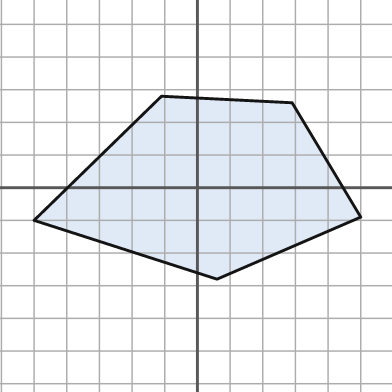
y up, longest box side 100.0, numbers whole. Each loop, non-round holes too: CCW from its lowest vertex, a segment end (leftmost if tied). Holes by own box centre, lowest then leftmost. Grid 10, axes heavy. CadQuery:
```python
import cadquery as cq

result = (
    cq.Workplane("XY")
    .moveTo(6.0, -28.0)
    .lineTo(50.0, -9.0)
    .lineTo(29.0, 26.0)
    .lineTo(-11.0, 28.0)
    .lineTo(-50.0, -10.0)
    .close()
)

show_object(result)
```